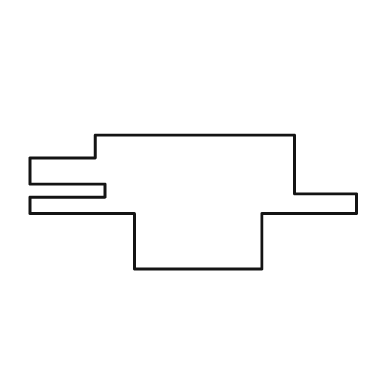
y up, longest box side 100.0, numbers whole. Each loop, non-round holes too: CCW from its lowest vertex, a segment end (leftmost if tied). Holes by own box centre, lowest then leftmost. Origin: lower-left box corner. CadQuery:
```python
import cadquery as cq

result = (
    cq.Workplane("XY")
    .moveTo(32.0, 0.0)
    .lineTo(71.0, 0.0)
    .lineTo(71.0, 17.0)
    .lineTo(100.0, 17.0)
    .lineTo(100.0, 23.0)
    .lineTo(81.0, 23.0)
    .lineTo(81.0, 41.0)
    .lineTo(20.0, 41.0)
    .lineTo(20.0, 34.0)
    .lineTo(0.0, 34.0)
    .lineTo(0.0, 26.0)
    .lineTo(23.0, 26.0)
    .lineTo(23.0, 22.0)
    .lineTo(0.0, 22.0)
    .lineTo(0.0, 17.0)
    .lineTo(32.0, 17.0)
    .close()
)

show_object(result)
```